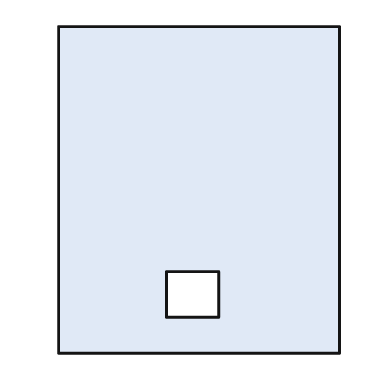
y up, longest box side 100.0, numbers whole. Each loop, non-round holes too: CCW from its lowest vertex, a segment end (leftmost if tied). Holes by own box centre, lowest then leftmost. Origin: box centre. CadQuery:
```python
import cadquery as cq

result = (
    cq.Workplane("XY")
    .moveTo(-43.0, -50.0)
    .lineTo(43.0, -50.0)
    .lineTo(43.0, 50.0)
    .lineTo(-43.0, 50.0)
    .close()
    .moveTo(-10.0, -39.0)
    .lineTo(6.0, -39.0)
    .lineTo(6.0, -25.0)
    .lineTo(-10.0, -25.0)
    .close()
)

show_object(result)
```